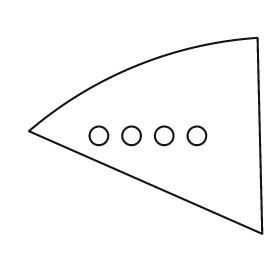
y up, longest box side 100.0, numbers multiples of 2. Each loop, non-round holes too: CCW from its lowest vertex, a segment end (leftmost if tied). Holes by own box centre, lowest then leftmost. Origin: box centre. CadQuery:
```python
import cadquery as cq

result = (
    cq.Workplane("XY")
    .moveTo(50.0, -42.0)
    .lineTo(48.0, 42.0)
    .threePointArc((-4.0, 30.0), (-50.0, 2.0))
    .close()
    .moveTo(-20.0, 0.0)
    .circle(4.0)
    .moveTo(-6.0, 0.0)
    .circle(4.0)
    .moveTo(8.0, 0.0)
    .circle(4.0)
    .moveTo(22.0, 0.0)
    .circle(4.0)
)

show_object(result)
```